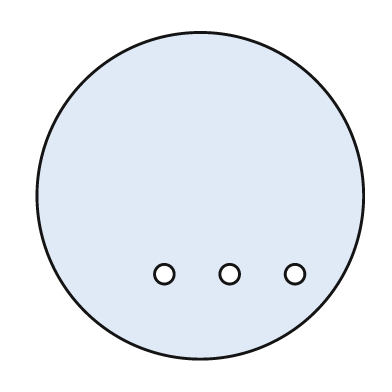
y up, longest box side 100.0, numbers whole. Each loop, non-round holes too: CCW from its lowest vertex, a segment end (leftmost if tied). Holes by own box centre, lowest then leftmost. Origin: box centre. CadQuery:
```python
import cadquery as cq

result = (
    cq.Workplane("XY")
    .moveTo(0.0, 0.0)
    .circle(50.0)
    .moveTo(-11.0, -24.0)
    .circle(3.0)
    .moveTo(9.0, -24.0)
    .circle(3.0)
    .moveTo(29.0, -24.0)
    .circle(3.0)
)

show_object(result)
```